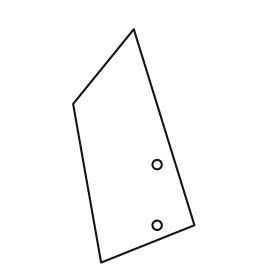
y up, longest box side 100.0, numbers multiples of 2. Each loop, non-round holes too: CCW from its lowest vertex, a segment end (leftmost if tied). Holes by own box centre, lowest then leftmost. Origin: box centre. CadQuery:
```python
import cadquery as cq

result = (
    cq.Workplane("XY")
    .moveTo(-14.0, -50.0)
    .lineTo(26.0, -34.0)
    .lineTo(0.0, 50.0)
    .lineTo(-26.0, 18.0)
    .close()
    .moveTo(10.0, -34.0)
    .circle(2.0)
    .moveTo(10.0, -8.0)
    .circle(2.0)
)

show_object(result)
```